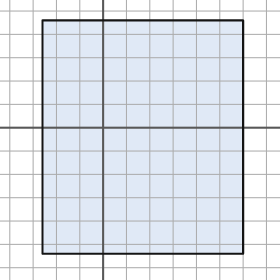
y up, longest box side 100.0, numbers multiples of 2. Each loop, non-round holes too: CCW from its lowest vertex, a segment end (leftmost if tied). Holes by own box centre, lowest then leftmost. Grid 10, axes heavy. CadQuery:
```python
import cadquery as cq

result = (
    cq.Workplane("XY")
    .moveTo(-26.0, -54.0)
    .lineTo(60.0, -54.0)
    .lineTo(60.0, 46.0)
    .lineTo(-26.0, 46.0)
    .close()
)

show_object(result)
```